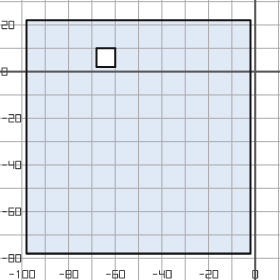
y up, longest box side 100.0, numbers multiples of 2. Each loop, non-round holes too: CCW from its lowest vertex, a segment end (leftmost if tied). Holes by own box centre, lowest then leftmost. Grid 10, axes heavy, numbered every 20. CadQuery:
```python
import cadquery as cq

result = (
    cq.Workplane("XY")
    .moveTo(-98.0, -78.0)
    .lineTo(-2.0, -78.0)
    .lineTo(-2.0, 22.0)
    .lineTo(-98.0, 22.0)
    .close()
    .moveTo(-68.0, 2.0)
    .lineTo(-60.0, 2.0)
    .lineTo(-60.0, 10.0)
    .lineTo(-68.0, 10.0)
    .close()
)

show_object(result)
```